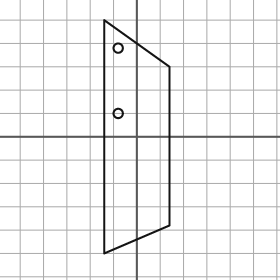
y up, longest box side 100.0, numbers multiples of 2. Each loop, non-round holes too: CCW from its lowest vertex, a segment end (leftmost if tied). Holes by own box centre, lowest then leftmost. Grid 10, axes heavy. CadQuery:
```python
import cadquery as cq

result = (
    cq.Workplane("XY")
    .moveTo(-14.0, -50.0)
    .lineTo(14.0, -38.0)
    .lineTo(14.0, 30.0)
    .lineTo(-14.0, 50.0)
    .close()
    .moveTo(-8.0, 10.0)
    .circle(2.0)
    .moveTo(-8.0, 38.0)
    .circle(2.0)
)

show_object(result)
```